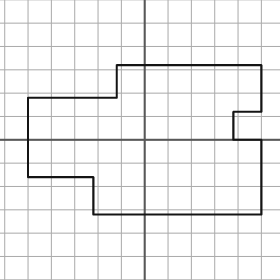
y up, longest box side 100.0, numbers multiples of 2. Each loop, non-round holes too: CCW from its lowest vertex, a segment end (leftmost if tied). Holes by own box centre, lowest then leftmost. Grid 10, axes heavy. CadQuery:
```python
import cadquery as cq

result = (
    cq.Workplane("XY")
    .moveTo(-22.0, -32.0)
    .lineTo(50.0, -32.0)
    .lineTo(50.0, 0.0)
    .lineTo(38.0, 0.0)
    .lineTo(38.0, 12.0)
    .lineTo(50.0, 12.0)
    .lineTo(50.0, 32.0)
    .lineTo(-12.0, 32.0)
    .lineTo(-12.0, 18.0)
    .lineTo(-50.0, 18.0)
    .lineTo(-50.0, -16.0)
    .lineTo(-22.0, -16.0)
    .close()
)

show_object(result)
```